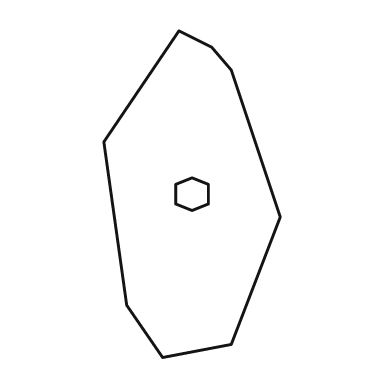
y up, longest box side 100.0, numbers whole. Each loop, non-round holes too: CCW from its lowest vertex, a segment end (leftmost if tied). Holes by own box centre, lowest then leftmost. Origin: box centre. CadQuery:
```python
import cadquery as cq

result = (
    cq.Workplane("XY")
    .moveTo(-9.0, -50.0)
    .lineTo(12.0, -46.0)
    .lineTo(27.0, -7.0)
    .lineTo(12.0, 38.0)
    .lineTo(6.0, 45.0)
    .lineTo(-4.0, 50.0)
    .lineTo(-27.0, 16.0)
    .lineTo(-20.0, -34.0)
    .close()
    .moveTo(0.0, -5.0)
    .lineTo(5.0, -3.0)
    .lineTo(5.0, 3.0)
    .lineTo(0.0, 5.0)
    .lineTo(-5.0, 3.0)
    .lineTo(-5.0, -3.0)
    .close()
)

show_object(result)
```